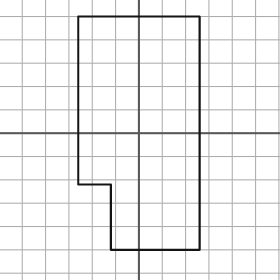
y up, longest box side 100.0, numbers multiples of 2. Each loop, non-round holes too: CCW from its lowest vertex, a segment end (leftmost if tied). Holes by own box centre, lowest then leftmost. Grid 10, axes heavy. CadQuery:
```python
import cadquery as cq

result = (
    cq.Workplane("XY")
    .moveTo(-12.0, -50.0)
    .lineTo(26.0, -50.0)
    .lineTo(26.0, 50.0)
    .lineTo(-26.0, 50.0)
    .lineTo(-26.0, -22.0)
    .lineTo(-12.0, -22.0)
    .close()
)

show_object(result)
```